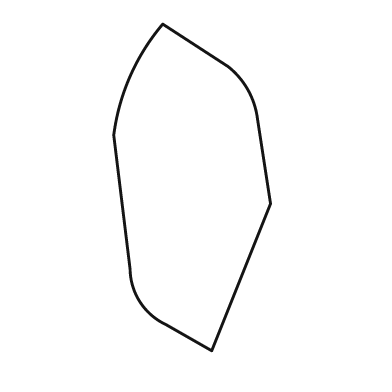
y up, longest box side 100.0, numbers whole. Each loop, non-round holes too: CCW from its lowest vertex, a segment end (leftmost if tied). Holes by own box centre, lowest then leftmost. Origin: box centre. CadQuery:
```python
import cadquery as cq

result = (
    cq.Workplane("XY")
    .moveTo(6.0, -50.0)
    .lineTo(24.0, -5.0)
    .lineTo(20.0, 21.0)
    .threePointArc((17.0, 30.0), (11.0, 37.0))
    .lineTo(-9.0, 50.0)
    .threePointArc((-19.0, 34.0), (-24.0, 16.0))
    .lineTo(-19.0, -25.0)
    .threePointArc((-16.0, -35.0), (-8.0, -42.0))
    .close()
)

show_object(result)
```